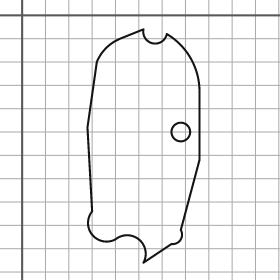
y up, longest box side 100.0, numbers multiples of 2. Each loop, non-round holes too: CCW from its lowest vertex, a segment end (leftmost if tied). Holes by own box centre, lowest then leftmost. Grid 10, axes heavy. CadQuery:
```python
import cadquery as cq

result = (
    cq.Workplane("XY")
    .moveTo(52.0, -106.0)
    .lineTo(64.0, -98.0)
    .threePointArc((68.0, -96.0), (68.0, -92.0))
    .lineTo(76.0, -62.0)
    .lineTo(76.0, -32.0)
    .threePointArc((72.0, -18.0), (62.0, -8.0))
    .threePointArc((56.0, -12.0), (52.0, -6.0))
    .lineTo(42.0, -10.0)
    .threePointArc((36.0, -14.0), (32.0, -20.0))
    .lineTo(28.0, -48.0)
    .lineTo(30.0, -84.0)
    .threePointArc((30.0, -94.0), (40.0, -96.0))
    .threePointArc((50.0, -96.0), (52.0, -106.0))
    .close()
    .moveTo(68.0, -50.0)
    .circle(4.0)
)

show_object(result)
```